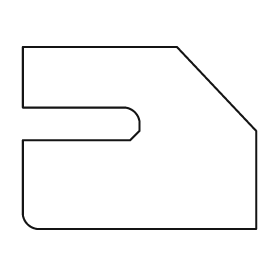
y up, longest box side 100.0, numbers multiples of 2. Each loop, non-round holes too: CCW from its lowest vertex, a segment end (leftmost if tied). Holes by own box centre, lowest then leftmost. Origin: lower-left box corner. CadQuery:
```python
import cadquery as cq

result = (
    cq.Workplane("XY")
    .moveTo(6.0, 0.0)
    .lineTo(100.0, 0.0)
    .lineTo(100.0, 42.0)
    .lineTo(66.0, 78.0)
    .lineTo(0.0, 78.0)
    .lineTo(0.0, 52.0)
    .lineTo(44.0, 52.0)
    .threePointArc((48.0, 50.0), (50.0, 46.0))
    .lineTo(50.0, 42.0)
    .lineTo(46.0, 38.0)
    .lineTo(0.0, 38.0)
    .lineTo(0.0, 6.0)
    .threePointArc((2.0, 2.0), (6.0, 0.0))
    .close()
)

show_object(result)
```